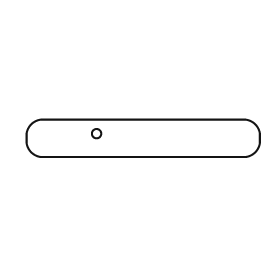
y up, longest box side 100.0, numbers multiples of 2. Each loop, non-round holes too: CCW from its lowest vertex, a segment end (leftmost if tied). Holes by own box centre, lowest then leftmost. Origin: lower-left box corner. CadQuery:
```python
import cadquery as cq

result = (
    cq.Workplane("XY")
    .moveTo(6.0, 0.0)
    .lineTo(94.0, 0.0)
    .threePointArc((98.0, 2.0), (100.0, 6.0))
    .lineTo(100.0, 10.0)
    .threePointArc((98.0, 14.0), (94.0, 16.0))
    .lineTo(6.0, 16.0)
    .threePointArc((2.0, 14.0), (0.0, 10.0))
    .lineTo(0.0, 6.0)
    .threePointArc((2.0, 2.0), (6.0, 0.0))
    .close()
    .moveTo(30.0, 10.0)
    .circle(2.0)
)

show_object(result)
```